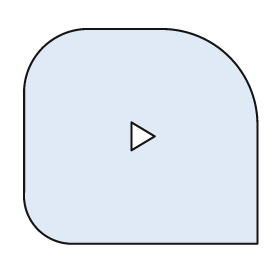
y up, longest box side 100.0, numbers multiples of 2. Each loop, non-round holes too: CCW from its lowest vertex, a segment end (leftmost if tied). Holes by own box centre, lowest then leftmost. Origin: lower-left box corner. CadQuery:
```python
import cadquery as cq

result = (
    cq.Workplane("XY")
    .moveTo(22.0, 0.0)
    .lineTo(100.0, 0.0)
    .lineTo(100.0, 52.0)
    .threePointArc((88.0, 80.0), (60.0, 92.0))
    .lineTo(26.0, 92.0)
    .threePointArc((8.0, 84.0), (0.0, 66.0))
    .lineTo(0.0, 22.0)
    .threePointArc((6.0, 6.0), (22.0, 0.0))
    .close()
    .moveTo(46.0, 40.0)
    .lineTo(56.0, 46.0)
    .lineTo(46.0, 52.0)
    .close()
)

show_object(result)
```